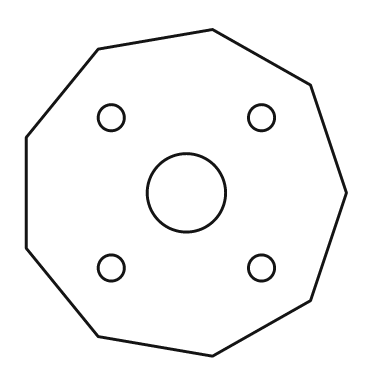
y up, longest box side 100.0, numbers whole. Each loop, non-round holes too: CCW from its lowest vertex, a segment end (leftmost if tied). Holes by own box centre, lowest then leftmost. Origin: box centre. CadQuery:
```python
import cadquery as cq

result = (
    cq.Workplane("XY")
    .moveTo(8.0, -50.0)
    .lineTo(38.0, -33.0)
    .lineTo(49.0, 0.0)
    .lineTo(38.0, 33.0)
    .lineTo(8.0, 50.0)
    .lineTo(-27.0, 44.0)
    .lineTo(-49.0, 17.0)
    .lineTo(-49.0, -17.0)
    .lineTo(-27.0, -44.0)
    .close()
    .moveTo(-23.0, -23.0)
    .circle(4.0)
    .moveTo(23.0, -23.0)
    .circle(4.0)
    .moveTo(0.0, 0.0)
    .circle(12.0)
    .moveTo(-23.0, 23.0)
    .circle(4.0)
    .moveTo(23.0, 23.0)
    .circle(4.0)
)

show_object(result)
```